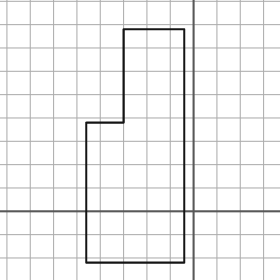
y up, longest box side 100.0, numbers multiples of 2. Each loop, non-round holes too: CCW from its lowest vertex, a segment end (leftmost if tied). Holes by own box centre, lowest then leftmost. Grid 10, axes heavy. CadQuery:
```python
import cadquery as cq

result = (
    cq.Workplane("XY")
    .moveTo(-46.0, -22.0)
    .lineTo(-4.0, -22.0)
    .lineTo(-4.0, 78.0)
    .lineTo(-30.0, 78.0)
    .lineTo(-30.0, 38.0)
    .lineTo(-46.0, 38.0)
    .close()
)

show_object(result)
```